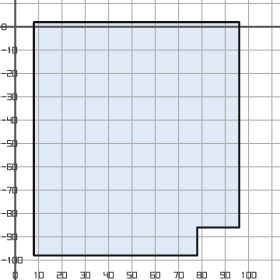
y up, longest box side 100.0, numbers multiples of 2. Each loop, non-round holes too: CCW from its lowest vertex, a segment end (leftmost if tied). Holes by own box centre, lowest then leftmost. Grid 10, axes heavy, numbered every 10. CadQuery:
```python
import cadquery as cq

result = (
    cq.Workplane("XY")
    .moveTo(8.0, -98.0)
    .lineTo(78.0, -98.0)
    .lineTo(78.0, -86.0)
    .lineTo(96.0, -86.0)
    .lineTo(96.0, 2.0)
    .lineTo(8.0, 2.0)
    .close()
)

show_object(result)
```